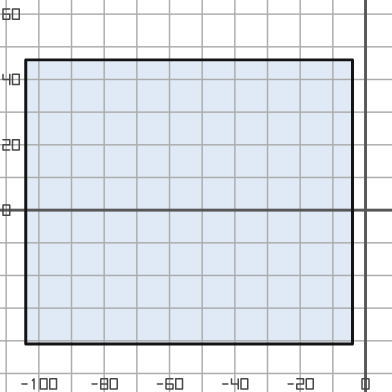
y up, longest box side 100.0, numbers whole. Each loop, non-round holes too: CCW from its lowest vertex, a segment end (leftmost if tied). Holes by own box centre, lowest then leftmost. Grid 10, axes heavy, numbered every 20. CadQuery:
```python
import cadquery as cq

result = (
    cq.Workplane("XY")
    .moveTo(-104.0, -41.0)
    .lineTo(-4.0, -41.0)
    .lineTo(-4.0, 46.0)
    .lineTo(-104.0, 46.0)
    .close()
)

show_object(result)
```